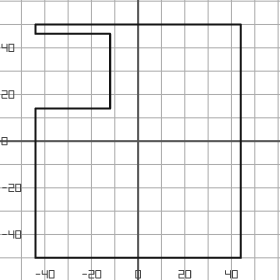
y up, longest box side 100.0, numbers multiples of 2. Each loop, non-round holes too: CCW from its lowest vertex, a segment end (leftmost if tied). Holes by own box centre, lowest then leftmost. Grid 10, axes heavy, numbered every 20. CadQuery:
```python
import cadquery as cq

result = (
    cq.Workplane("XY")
    .moveTo(-44.0, -50.0)
    .lineTo(44.0, -50.0)
    .lineTo(44.0, 50.0)
    .lineTo(-44.0, 50.0)
    .lineTo(-44.0, 46.0)
    .lineTo(-12.0, 46.0)
    .lineTo(-12.0, 14.0)
    .lineTo(-44.0, 14.0)
    .close()
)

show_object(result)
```